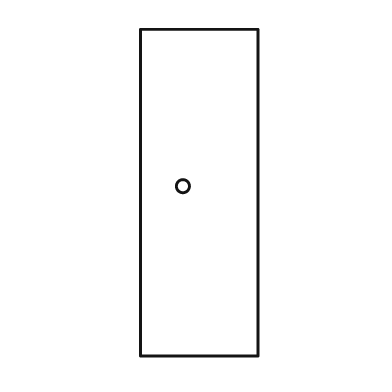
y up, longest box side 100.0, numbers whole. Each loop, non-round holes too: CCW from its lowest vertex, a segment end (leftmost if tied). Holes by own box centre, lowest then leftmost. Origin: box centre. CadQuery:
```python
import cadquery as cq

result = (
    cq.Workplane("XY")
    .moveTo(-18.0, -50.0)
    .lineTo(18.0, -50.0)
    .lineTo(18.0, 50.0)
    .lineTo(-18.0, 50.0)
    .close()
    .moveTo(-5.0, 2.0)
    .circle(2.0)
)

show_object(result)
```